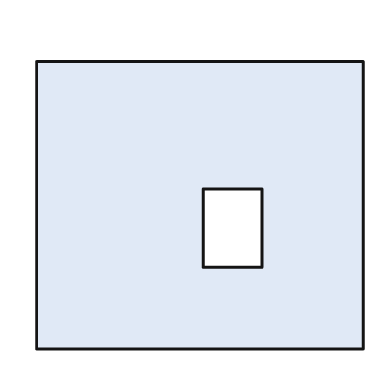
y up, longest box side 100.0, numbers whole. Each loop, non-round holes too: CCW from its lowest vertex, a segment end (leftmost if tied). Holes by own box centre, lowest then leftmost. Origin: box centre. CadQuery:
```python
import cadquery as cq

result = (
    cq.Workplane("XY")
    .moveTo(-50.0, -44.0)
    .lineTo(50.0, -44.0)
    .lineTo(50.0, 44.0)
    .lineTo(-50.0, 44.0)
    .close()
    .moveTo(1.0, -19.0)
    .lineTo(19.0, -19.0)
    .lineTo(19.0, 5.0)
    .lineTo(1.0, 5.0)
    .close()
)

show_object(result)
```